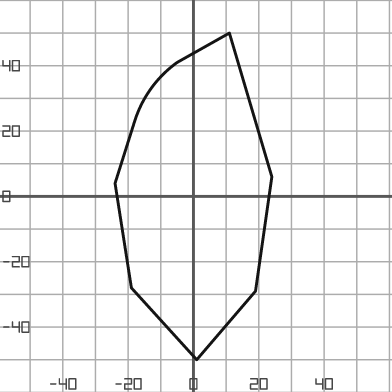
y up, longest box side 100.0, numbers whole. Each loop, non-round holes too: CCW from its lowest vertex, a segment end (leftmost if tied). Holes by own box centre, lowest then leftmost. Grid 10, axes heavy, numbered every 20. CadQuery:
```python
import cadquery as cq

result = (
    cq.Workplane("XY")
    .moveTo(1.0, -50.0)
    .lineTo(19.0, -29.0)
    .lineTo(24.0, 6.0)
    .lineTo(11.0, 50.0)
    .lineTo(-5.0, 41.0)
    .threePointArc((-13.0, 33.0), (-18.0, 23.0))
    .lineTo(-24.0, 4.0)
    .lineTo(-19.0, -28.0)
    .close()
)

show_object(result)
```